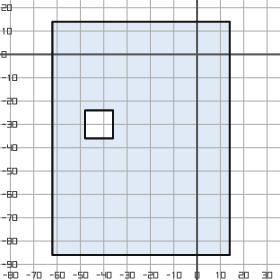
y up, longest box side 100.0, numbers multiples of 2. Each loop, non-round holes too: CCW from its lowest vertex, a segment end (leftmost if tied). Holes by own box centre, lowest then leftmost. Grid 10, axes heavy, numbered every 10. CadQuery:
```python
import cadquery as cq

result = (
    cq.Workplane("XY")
    .moveTo(-62.0, -86.0)
    .lineTo(14.0, -86.0)
    .lineTo(14.0, 14.0)
    .lineTo(-62.0, 14.0)
    .close()
    .moveTo(-48.0, -36.0)
    .lineTo(-36.0, -36.0)
    .lineTo(-36.0, -24.0)
    .lineTo(-48.0, -24.0)
    .close()
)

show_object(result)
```